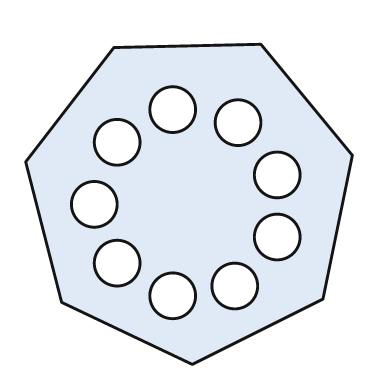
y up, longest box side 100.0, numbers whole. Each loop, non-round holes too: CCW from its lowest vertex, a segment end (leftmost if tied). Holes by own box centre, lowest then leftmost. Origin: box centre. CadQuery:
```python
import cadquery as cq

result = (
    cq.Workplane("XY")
    .moveTo(1.0, -49.0)
    .lineTo(41.0, -29.0)
    .lineTo(50.0, 15.0)
    .lineTo(22.0, 49.0)
    .lineTo(-23.0, 48.0)
    .lineTo(-50.0, 13.0)
    .lineTo(-39.0, -30.0)
    .close()
    .moveTo(-5.0, -28.0)
    .circle(7.0)
    .moveTo(14.0, -25.0)
    .circle(7.0)
    .moveTo(-22.0, -18.0)
    .circle(7.0)
    .moveTo(27.0, -10.0)
    .circle(7.0)
    .moveTo(-29.0, 0.0)
    .circle(7.0)
    .moveTo(27.0, 9.0)
    .circle(7.0)
    .moveTo(-22.0, 19.0)
    .circle(7.0)
    .moveTo(15.0, 25.0)
    .circle(7.0)
    .moveTo(-5.0, 29.0)
    .circle(7.0)
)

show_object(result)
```